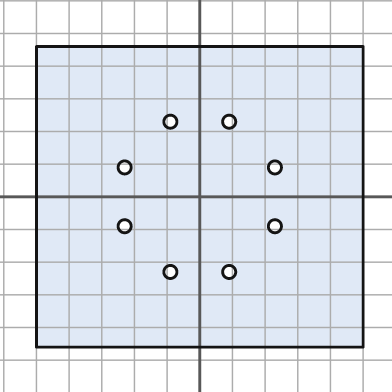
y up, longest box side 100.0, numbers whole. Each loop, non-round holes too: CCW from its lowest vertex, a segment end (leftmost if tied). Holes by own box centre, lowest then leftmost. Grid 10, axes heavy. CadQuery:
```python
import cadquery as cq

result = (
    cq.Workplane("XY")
    .moveTo(-50.0, -46.0)
    .lineTo(50.0, -46.0)
    .lineTo(50.0, 46.0)
    .lineTo(-50.0, 46.0)
    .close()
    .moveTo(-9.0, -23.0)
    .circle(2.0)
    .moveTo(9.0, -23.0)
    .circle(2.0)
    .moveTo(-23.0, -9.0)
    .circle(2.0)
    .moveTo(23.0, -9.0)
    .circle(2.0)
    .moveTo(-23.0, 9.0)
    .circle(2.0)
    .moveTo(23.0, 9.0)
    .circle(2.0)
    .moveTo(-9.0, 23.0)
    .circle(2.0)
    .moveTo(9.0, 23.0)
    .circle(2.0)
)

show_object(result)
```